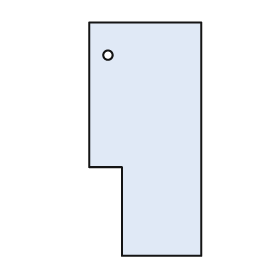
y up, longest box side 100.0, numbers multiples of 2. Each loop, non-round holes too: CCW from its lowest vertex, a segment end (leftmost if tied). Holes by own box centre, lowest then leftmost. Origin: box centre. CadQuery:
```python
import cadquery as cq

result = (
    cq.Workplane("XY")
    .moveTo(-10.0, -50.0)
    .lineTo(24.0, -50.0)
    .lineTo(24.0, 50.0)
    .lineTo(-24.0, 50.0)
    .lineTo(-24.0, -12.0)
    .lineTo(-10.0, -12.0)
    .close()
    .moveTo(-16.0, 36.0)
    .circle(2.0)
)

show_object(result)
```